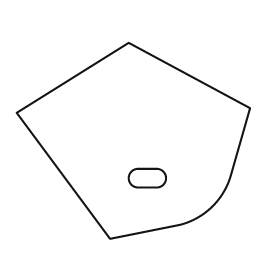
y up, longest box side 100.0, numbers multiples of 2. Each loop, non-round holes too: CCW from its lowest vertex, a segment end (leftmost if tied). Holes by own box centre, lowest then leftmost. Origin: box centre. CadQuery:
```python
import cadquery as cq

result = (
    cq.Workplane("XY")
    .moveTo(-10.0, -42.0)
    .lineTo(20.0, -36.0)
    .threePointArc((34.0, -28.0), (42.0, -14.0))
    .lineTo(50.0, 14.0)
    .lineTo(-2.0, 42.0)
    .lineTo(-50.0, 12.0)
    .close()
    .moveTo(2.0, -20.0)
    .lineTo(10.0, -20.0)
    .threePointArc((14.0, -16.0), (10.0, -12.0))
    .lineTo(2.0, -12.0)
    .threePointArc((-2.0, -16.0), (2.0, -20.0))
    .close()
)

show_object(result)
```